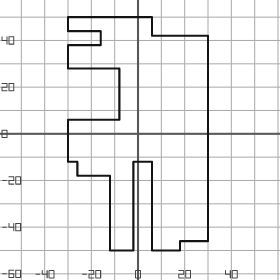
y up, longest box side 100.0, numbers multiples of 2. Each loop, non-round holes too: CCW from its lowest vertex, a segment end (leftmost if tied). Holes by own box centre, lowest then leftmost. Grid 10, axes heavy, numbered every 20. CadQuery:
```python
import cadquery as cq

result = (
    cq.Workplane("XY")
    .moveTo(-12.0, -50.0)
    .lineTo(-2.0, -50.0)
    .lineTo(-2.0, -12.0)
    .lineTo(6.0, -12.0)
    .lineTo(6.0, -50.0)
    .lineTo(18.0, -50.0)
    .lineTo(18.0, -46.0)
    .lineTo(30.0, -46.0)
    .lineTo(30.0, 42.0)
    .lineTo(6.0, 42.0)
    .lineTo(6.0, 50.0)
    .lineTo(-30.0, 50.0)
    .lineTo(-30.0, 44.0)
    .lineTo(-16.0, 44.0)
    .lineTo(-16.0, 38.0)
    .lineTo(-30.0, 38.0)
    .lineTo(-30.0, 28.0)
    .lineTo(-8.0, 28.0)
    .lineTo(-8.0, 6.0)
    .lineTo(-30.0, 6.0)
    .lineTo(-30.0, -12.0)
    .lineTo(-26.0, -12.0)
    .lineTo(-26.0, -18.0)
    .lineTo(-12.0, -18.0)
    .close()
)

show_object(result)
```